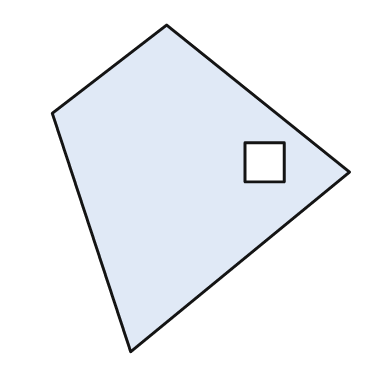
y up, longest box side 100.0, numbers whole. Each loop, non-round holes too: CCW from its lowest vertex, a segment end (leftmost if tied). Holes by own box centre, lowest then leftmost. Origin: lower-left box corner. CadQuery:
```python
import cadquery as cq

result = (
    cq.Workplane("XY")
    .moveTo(24.0, 0.0)
    .lineTo(91.0, 55.0)
    .lineTo(35.0, 100.0)
    .lineTo(0.0, 73.0)
    .close()
    .moveTo(59.0, 52.0)
    .lineTo(71.0, 52.0)
    .lineTo(71.0, 64.0)
    .lineTo(59.0, 64.0)
    .close()
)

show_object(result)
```